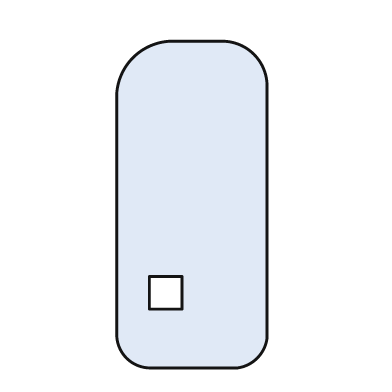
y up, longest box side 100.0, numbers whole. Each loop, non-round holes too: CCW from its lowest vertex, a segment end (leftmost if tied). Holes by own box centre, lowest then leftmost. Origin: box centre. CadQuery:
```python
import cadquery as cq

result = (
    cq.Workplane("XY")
    .moveTo(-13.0, -50.0)
    .lineTo(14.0, -50.0)
    .threePointArc((20.0, -47.0), (23.0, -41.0))
    .lineTo(23.0, 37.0)
    .threePointArc((19.0, 46.0), (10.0, 50.0))
    .lineTo(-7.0, 50.0)
    .threePointArc((-18.0, 45.0), (-23.0, 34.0))
    .lineTo(-23.0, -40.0)
    .threePointArc((-20.0, -47.0), (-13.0, -50.0))
    .close()
    .moveTo(-13.0, -32.0)
    .lineTo(-3.0, -32.0)
    .lineTo(-3.0, -22.0)
    .lineTo(-13.0, -22.0)
    .close()
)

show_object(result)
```